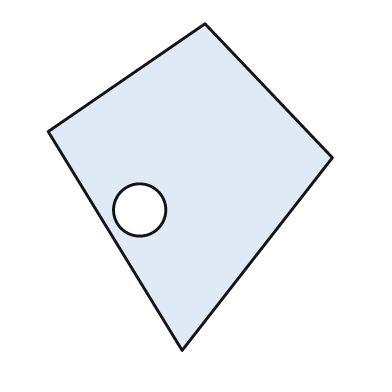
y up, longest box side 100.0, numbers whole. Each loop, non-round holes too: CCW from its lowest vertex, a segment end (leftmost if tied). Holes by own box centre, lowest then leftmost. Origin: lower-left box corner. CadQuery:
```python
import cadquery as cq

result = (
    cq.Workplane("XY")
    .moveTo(41.0, 0.0)
    .lineTo(87.0, 59.0)
    .lineTo(48.0, 100.0)
    .lineTo(0.0, 67.0)
    .close()
    .moveTo(28.0, 43.0)
    .circle(8.0)
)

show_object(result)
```